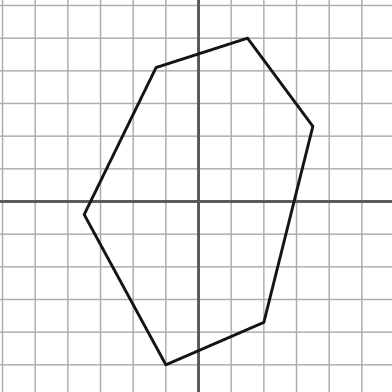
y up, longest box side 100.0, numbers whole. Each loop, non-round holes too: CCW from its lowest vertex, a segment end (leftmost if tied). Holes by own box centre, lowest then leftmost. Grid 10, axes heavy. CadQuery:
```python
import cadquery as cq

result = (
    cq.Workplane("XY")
    .moveTo(-10.0, -50.0)
    .lineTo(20.0, -37.0)
    .lineTo(35.0, 23.0)
    .lineTo(15.0, 50.0)
    .lineTo(-13.0, 41.0)
    .lineTo(-35.0, -4.0)
    .close()
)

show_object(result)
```